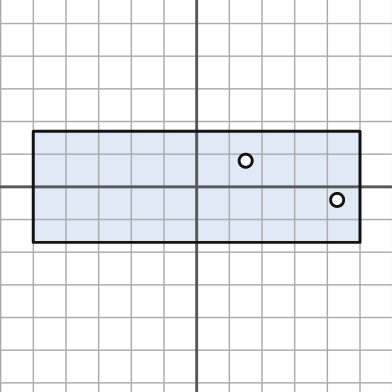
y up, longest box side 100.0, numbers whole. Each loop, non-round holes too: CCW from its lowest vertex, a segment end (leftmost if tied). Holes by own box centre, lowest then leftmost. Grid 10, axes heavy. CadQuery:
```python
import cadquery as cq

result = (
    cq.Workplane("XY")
    .moveTo(-50.0, -17.0)
    .lineTo(50.0, -17.0)
    .lineTo(50.0, 17.0)
    .lineTo(-50.0, 17.0)
    .close()
    .moveTo(43.0, -4.0)
    .circle(2.0)
    .moveTo(15.0, 8.0)
    .circle(2.0)
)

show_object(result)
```